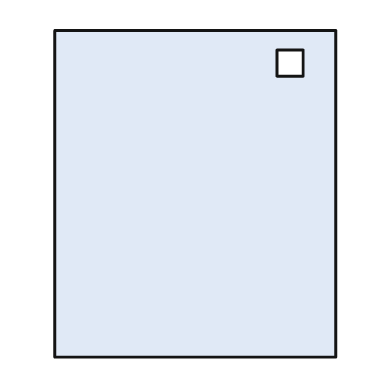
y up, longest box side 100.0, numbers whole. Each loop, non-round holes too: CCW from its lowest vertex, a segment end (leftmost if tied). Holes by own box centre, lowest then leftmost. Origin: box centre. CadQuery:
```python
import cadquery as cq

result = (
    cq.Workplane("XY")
    .moveTo(-43.0, -50.0)
    .lineTo(43.0, -50.0)
    .lineTo(43.0, 50.0)
    .lineTo(-43.0, 50.0)
    .close()
    .moveTo(25.0, 36.0)
    .lineTo(33.0, 36.0)
    .lineTo(33.0, 44.0)
    .lineTo(25.0, 44.0)
    .close()
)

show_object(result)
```